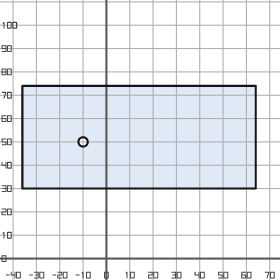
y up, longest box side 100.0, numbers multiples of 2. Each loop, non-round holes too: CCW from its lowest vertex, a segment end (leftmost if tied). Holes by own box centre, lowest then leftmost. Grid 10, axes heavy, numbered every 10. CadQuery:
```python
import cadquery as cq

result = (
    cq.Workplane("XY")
    .moveTo(-36.0, 30.0)
    .lineTo(64.0, 30.0)
    .lineTo(64.0, 74.0)
    .lineTo(-36.0, 74.0)
    .close()
    .moveTo(-10.0, 50.0)
    .circle(2.0)
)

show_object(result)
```